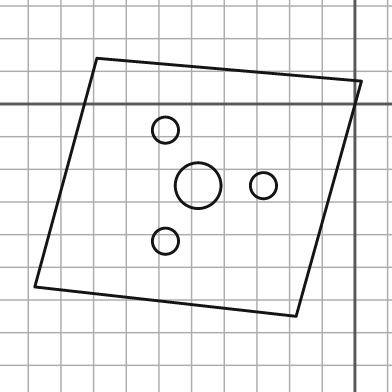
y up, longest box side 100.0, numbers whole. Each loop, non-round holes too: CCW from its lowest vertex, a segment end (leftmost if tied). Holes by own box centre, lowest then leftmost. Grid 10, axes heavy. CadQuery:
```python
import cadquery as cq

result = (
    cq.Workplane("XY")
    .moveTo(-18.0, -65.0)
    .lineTo(2.0, 7.0)
    .lineTo(-79.0, 14.0)
    .lineTo(-98.0, -56.0)
    .close()
    .moveTo(-58.0, -42.0)
    .circle(4.0)
    .moveTo(-48.0, -25.0)
    .circle(7.0)
    .moveTo(-28.0, -25.0)
    .circle(4.0)
    .moveTo(-58.0, -8.0)
    .circle(4.0)
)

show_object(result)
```